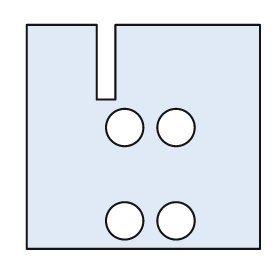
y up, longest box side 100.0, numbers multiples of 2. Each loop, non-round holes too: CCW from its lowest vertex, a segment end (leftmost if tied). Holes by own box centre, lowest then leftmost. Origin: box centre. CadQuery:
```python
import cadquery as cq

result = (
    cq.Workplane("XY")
    .moveTo(-50.0, -48.0)
    .lineTo(50.0, -48.0)
    .lineTo(50.0, 48.0)
    .lineTo(-12.0, 48.0)
    .lineTo(-12.0, 16.0)
    .lineTo(-20.0, 16.0)
    .lineTo(-20.0, 48.0)
    .lineTo(-50.0, 48.0)
    .close()
    .moveTo(-8.0, -36.0)
    .circle(8.0)
    .moveTo(14.0, -36.0)
    .circle(8.0)
    .moveTo(-8.0, 4.0)
    .circle(8.0)
    .moveTo(14.0, 4.0)
    .circle(8.0)
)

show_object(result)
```